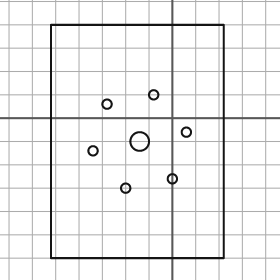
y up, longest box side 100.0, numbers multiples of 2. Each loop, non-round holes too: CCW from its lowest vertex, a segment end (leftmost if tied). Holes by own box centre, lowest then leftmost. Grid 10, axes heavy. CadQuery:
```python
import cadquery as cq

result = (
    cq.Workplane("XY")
    .moveTo(-52.0, -60.0)
    .lineTo(22.0, -60.0)
    .lineTo(22.0, 40.0)
    .lineTo(-52.0, 40.0)
    .close()
    .moveTo(-20.0, -30.0)
    .circle(2.0)
    .moveTo(0.0, -26.0)
    .circle(2.0)
    .moveTo(-34.0, -14.0)
    .circle(2.0)
    .moveTo(-14.0, -10.0)
    .circle(4.0)
    .moveTo(6.0, -6.0)
    .circle(2.0)
    .moveTo(-28.0, 6.0)
    .circle(2.0)
    .moveTo(-8.0, 10.0)
    .circle(2.0)
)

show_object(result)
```